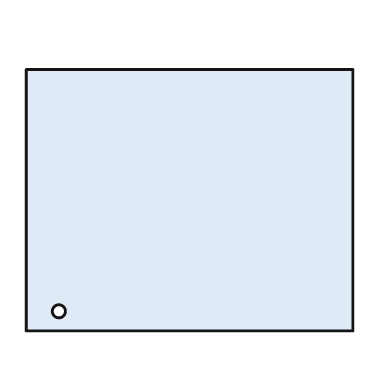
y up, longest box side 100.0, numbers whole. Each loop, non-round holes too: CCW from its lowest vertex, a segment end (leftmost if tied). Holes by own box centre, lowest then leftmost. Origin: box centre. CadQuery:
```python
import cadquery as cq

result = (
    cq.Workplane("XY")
    .moveTo(-50.0, -40.0)
    .lineTo(50.0, -40.0)
    .lineTo(50.0, 40.0)
    .lineTo(-50.0, 40.0)
    .close()
    .moveTo(-40.0, -34.0)
    .circle(2.0)
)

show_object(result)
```